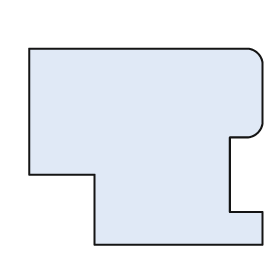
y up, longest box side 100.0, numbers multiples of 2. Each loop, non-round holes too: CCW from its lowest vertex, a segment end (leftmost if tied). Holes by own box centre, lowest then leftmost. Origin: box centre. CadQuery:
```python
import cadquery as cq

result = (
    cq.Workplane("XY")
    .moveTo(-22.0, -42.0)
    .lineTo(50.0, -42.0)
    .lineTo(50.0, -28.0)
    .lineTo(36.0, -28.0)
    .lineTo(36.0, 4.0)
    .lineTo(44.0, 4.0)
    .threePointArc((48.0, 6.0), (50.0, 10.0))
    .lineTo(50.0, 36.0)
    .threePointArc((48.0, 40.0), (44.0, 42.0))
    .lineTo(-50.0, 42.0)
    .lineTo(-50.0, -12.0)
    .lineTo(-22.0, -12.0)
    .close()
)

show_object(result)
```